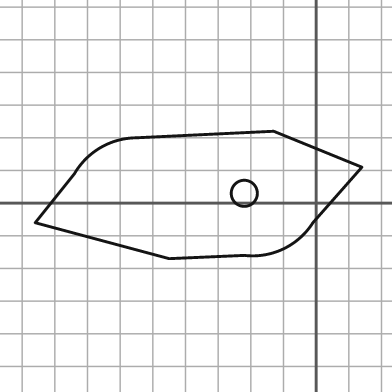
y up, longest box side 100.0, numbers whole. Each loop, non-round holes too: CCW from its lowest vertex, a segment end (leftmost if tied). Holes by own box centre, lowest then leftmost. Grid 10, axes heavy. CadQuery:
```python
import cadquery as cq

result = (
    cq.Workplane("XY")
    .moveTo(-45.0, -17.0)
    .lineTo(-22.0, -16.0)
    .threePointArc((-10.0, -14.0), (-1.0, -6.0))
    .lineTo(14.0, 11.0)
    .lineTo(-13.0, 22.0)
    .lineTo(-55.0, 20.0)
    .threePointArc((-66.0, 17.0), (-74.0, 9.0))
    .lineTo(-86.0, -6.0)
    .close()
    .moveTo(-22.0, 3.0)
    .circle(4.0)
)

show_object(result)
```